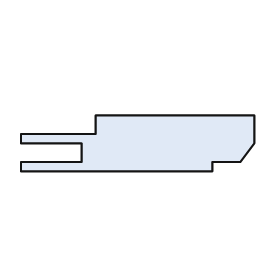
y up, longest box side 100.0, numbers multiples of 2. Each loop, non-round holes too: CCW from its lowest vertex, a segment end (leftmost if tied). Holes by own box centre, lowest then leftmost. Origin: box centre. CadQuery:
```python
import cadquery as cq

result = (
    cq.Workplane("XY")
    .moveTo(-50.0, -12.0)
    .lineTo(32.0, -12.0)
    .lineTo(32.0, -8.0)
    .lineTo(44.0, -8.0)
    .lineTo(50.0, 0.0)
    .lineTo(50.0, 12.0)
    .lineTo(-18.0, 12.0)
    .lineTo(-18.0, 4.0)
    .lineTo(-50.0, 4.0)
    .lineTo(-50.0, 0.0)
    .lineTo(-24.0, 0.0)
    .lineTo(-24.0, -8.0)
    .lineTo(-50.0, -8.0)
    .close()
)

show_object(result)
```